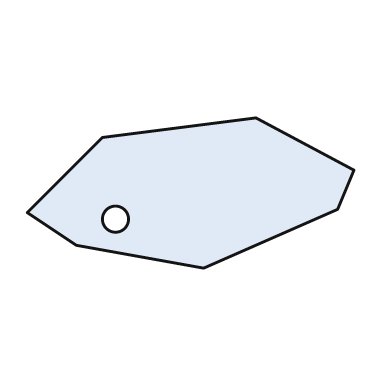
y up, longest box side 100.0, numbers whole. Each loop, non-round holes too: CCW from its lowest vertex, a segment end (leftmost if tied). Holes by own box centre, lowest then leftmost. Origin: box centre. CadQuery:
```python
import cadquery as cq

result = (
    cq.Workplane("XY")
    .moveTo(4.0, -23.0)
    .lineTo(45.0, -5.0)
    .lineTo(50.0, 7.0)
    .lineTo(20.0, 23.0)
    .lineTo(-27.0, 17.0)
    .lineTo(-50.0, -6.0)
    .lineTo(-35.0, -16.0)
    .close()
    .moveTo(-23.0, -8.0)
    .circle(4.0)
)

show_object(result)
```